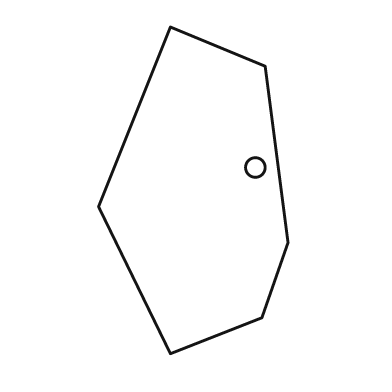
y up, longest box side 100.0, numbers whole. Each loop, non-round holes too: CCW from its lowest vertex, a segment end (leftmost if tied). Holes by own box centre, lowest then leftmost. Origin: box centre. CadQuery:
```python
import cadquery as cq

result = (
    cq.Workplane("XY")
    .moveTo(-7.0, -50.0)
    .lineTo(21.0, -39.0)
    .lineTo(29.0, -16.0)
    .lineTo(22.0, 38.0)
    .lineTo(-7.0, 50.0)
    .lineTo(-29.0, -5.0)
    .close()
    .moveTo(19.0, 7.0)
    .circle(3.0)
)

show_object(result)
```